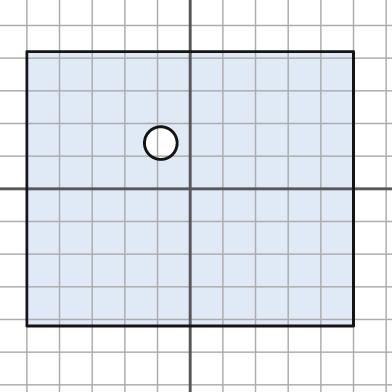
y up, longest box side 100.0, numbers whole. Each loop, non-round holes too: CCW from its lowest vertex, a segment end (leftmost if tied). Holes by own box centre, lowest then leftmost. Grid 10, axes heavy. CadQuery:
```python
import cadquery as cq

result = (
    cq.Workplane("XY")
    .moveTo(-50.0, -42.0)
    .lineTo(50.0, -42.0)
    .lineTo(50.0, 42.0)
    .lineTo(-50.0, 42.0)
    .close()
    .moveTo(-9.0, 14.0)
    .circle(5.0)
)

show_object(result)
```